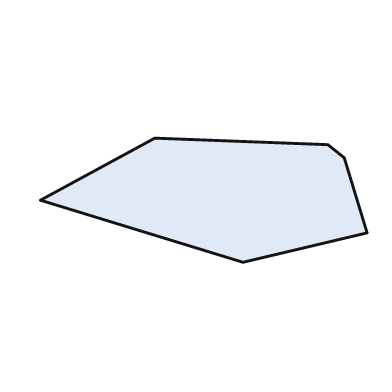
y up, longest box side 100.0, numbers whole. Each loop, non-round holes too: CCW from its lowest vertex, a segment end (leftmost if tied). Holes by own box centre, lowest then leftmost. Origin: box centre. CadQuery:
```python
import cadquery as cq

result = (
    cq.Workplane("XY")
    .moveTo(12.0, -19.0)
    .lineTo(50.0, -10.0)
    .lineTo(43.0, 13.0)
    .lineTo(38.0, 17.0)
    .lineTo(-15.0, 19.0)
    .lineTo(-50.0, 0.0)
    .close()
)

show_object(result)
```